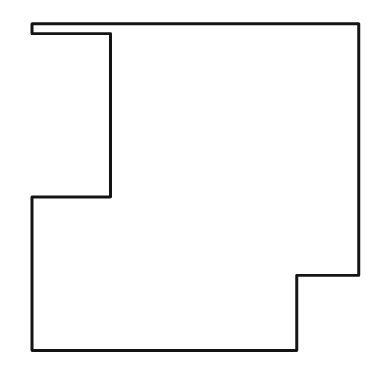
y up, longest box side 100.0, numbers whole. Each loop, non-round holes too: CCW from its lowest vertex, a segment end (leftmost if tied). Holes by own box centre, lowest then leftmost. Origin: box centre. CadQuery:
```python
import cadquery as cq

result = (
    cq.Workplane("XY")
    .moveTo(-50.0, -50.0)
    .lineTo(31.0, -50.0)
    .lineTo(31.0, -27.0)
    .lineTo(50.0, -27.0)
    .lineTo(50.0, 50.0)
    .lineTo(-50.0, 50.0)
    .lineTo(-50.0, 47.0)
    .lineTo(-26.0, 47.0)
    .lineTo(-26.0, -3.0)
    .lineTo(-50.0, -3.0)
    .close()
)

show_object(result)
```